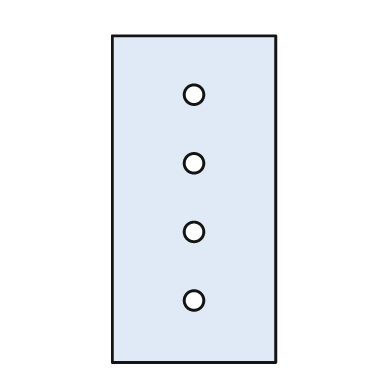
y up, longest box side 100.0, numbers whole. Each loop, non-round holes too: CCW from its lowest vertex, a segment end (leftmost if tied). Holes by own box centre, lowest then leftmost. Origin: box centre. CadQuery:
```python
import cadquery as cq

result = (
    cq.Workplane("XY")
    .moveTo(-25.0, -50.0)
    .lineTo(25.0, -50.0)
    .lineTo(25.0, 50.0)
    .lineTo(-25.0, 50.0)
    .close()
    .moveTo(0.0, -31.0)
    .circle(3.0)
    .moveTo(0.0, -10.0)
    .circle(3.0)
    .moveTo(0.0, 11.0)
    .circle(3.0)
    .moveTo(0.0, 32.0)
    .circle(3.0)
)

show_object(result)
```